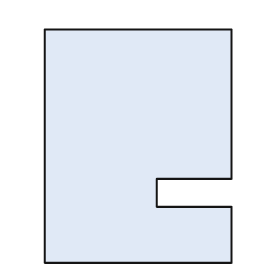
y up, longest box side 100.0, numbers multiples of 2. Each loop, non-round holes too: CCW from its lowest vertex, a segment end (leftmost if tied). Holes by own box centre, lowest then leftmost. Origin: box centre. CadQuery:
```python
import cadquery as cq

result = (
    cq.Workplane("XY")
    .moveTo(-40.0, -50.0)
    .lineTo(40.0, -50.0)
    .lineTo(40.0, -26.0)
    .lineTo(8.0, -26.0)
    .lineTo(8.0, -14.0)
    .lineTo(40.0, -14.0)
    .lineTo(40.0, 50.0)
    .lineTo(-40.0, 50.0)
    .close()
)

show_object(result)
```